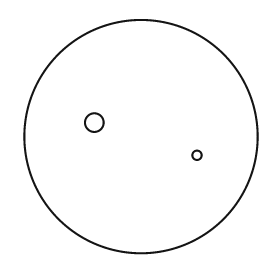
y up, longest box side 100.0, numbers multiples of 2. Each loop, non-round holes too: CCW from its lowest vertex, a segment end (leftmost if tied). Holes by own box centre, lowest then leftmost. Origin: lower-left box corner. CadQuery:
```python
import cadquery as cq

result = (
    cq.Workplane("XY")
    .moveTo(50.0, 50.0)
    .circle(50.0)
    .moveTo(74.0, 42.0)
    .circle(2.0)
    .moveTo(30.0, 56.0)
    .circle(4.0)
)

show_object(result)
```